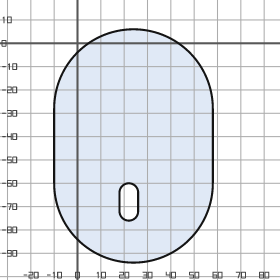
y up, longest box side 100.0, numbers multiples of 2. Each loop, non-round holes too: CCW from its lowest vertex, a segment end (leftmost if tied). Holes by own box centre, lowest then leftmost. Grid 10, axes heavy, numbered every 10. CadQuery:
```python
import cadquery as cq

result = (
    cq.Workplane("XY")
    .moveTo(-10.0, -60.0)
    .threePointArc((24.0, -94.0), (58.0, -60.0))
    .lineTo(58.0, -28.0)
    .threePointArc((24.0, 6.0), (-10.0, -28.0))
    .close()
    .moveTo(18.0, -72.0)
    .threePointArc((22.0, -76.0), (26.0, -72.0))
    .lineTo(26.0, -64.0)
    .threePointArc((22.0, -60.0), (18.0, -64.0))
    .close()
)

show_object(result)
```